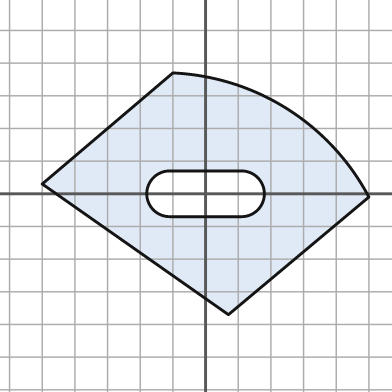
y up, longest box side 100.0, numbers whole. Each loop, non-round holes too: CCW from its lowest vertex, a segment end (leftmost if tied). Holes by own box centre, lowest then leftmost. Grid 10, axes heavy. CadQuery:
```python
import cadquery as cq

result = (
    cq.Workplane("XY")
    .moveTo(7.0, -37.0)
    .lineTo(50.0, -1.0)
    .threePointArc((25.0, 26.0), (-10.0, 37.0))
    .lineTo(-50.0, 3.0)
    .close()
    .moveTo(-11.0, -7.0)
    .lineTo(11.0, -7.0)
    .threePointArc((18.0, 0.0), (11.0, 7.0))
    .lineTo(-11.0, 7.0)
    .threePointArc((-18.0, 0.0), (-11.0, -7.0))
    .close()
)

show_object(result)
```